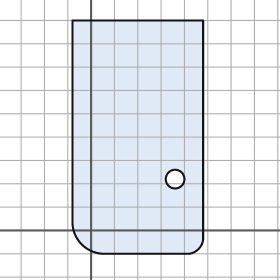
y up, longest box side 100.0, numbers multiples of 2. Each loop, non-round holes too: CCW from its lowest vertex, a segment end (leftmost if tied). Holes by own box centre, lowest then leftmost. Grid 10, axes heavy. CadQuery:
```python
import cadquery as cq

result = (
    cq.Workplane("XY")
    .moveTo(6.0, -10.0)
    .lineTo(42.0, -10.0)
    .threePointArc((46.0, -8.0), (48.0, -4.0))
    .lineTo(48.0, 90.0)
    .lineTo(-8.0, 90.0)
    .lineTo(-8.0, 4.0)
    .threePointArc((-4.0, -6.0), (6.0, -10.0))
    .close()
    .moveTo(36.0, 22.0)
    .circle(4.0)
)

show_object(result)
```